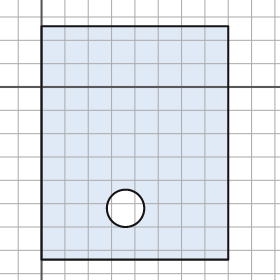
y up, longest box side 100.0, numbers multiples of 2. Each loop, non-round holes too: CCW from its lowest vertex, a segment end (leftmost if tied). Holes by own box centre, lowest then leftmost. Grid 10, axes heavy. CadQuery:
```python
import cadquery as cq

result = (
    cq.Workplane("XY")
    .moveTo(0.0, -74.0)
    .lineTo(80.0, -74.0)
    .lineTo(80.0, 26.0)
    .lineTo(0.0, 26.0)
    .close()
    .moveTo(36.0, -52.0)
    .circle(8.0)
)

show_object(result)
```